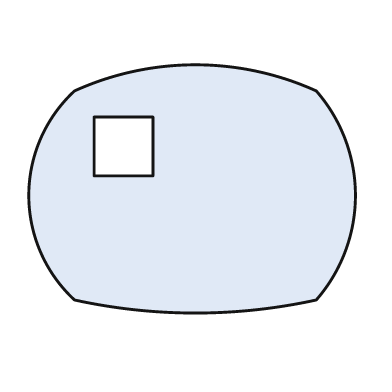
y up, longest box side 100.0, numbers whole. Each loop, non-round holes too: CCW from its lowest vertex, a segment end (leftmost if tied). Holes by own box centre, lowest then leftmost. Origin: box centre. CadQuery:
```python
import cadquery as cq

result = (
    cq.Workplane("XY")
    .moveTo(-36.0, -34.0)
    .threePointArc((1.0, -38.0), (38.0, -34.0))
    .threePointArc((50.0, -2.0), (38.0, 30.0))
    .threePointArc((1.0, 38.0), (-36.0, 30.0))
    .threePointArc((-50.0, -2.0), (-36.0, -34.0))
    .close()
    .moveTo(-30.0, 4.0)
    .lineTo(-12.0, 4.0)
    .lineTo(-12.0, 22.0)
    .lineTo(-30.0, 22.0)
    .close()
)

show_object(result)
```